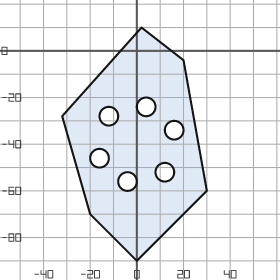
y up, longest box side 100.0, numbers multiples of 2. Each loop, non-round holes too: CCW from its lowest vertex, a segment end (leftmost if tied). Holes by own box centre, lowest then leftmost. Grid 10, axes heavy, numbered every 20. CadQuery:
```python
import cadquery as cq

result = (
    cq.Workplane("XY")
    .moveTo(0.0, -90.0)
    .lineTo(30.0, -60.0)
    .lineTo(20.0, -4.0)
    .lineTo(2.0, 10.0)
    .lineTo(-32.0, -28.0)
    .lineTo(-20.0, -70.0)
    .close()
    .moveTo(-4.0, -56.0)
    .circle(4.0)
    .moveTo(12.0, -52.0)
    .circle(4.0)
    .moveTo(-16.0, -46.0)
    .circle(4.0)
    .moveTo(16.0, -34.0)
    .circle(4.0)
    .moveTo(-12.0, -28.0)
    .circle(4.0)
    .moveTo(4.0, -24.0)
    .circle(4.0)
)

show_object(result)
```